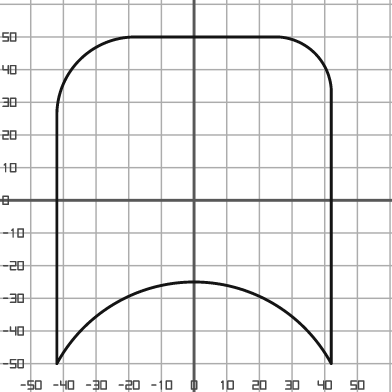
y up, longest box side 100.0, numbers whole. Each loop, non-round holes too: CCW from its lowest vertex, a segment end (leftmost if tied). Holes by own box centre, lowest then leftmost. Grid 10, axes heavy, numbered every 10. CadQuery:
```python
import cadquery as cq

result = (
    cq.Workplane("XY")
    .moveTo(-42.0, -50.0)
    .threePointArc((0.0, -25.0), (42.0, -50.0))
    .lineTo(42.0, 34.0)
    .threePointArc((37.0, 45.0), (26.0, 50.0))
    .lineTo(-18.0, 50.0)
    .threePointArc((-35.0, 43.0), (-42.0, 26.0))
    .close()
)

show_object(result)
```